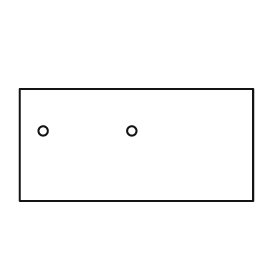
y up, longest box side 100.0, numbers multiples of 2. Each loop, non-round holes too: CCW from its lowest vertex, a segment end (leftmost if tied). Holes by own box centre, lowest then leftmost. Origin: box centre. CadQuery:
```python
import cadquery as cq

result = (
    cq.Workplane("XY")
    .moveTo(-50.0, -24.0)
    .lineTo(50.0, -24.0)
    .lineTo(50.0, 24.0)
    .lineTo(-50.0, 24.0)
    .close()
    .moveTo(-40.0, 6.0)
    .circle(2.0)
    .moveTo(-2.0, 6.0)
    .circle(2.0)
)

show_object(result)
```